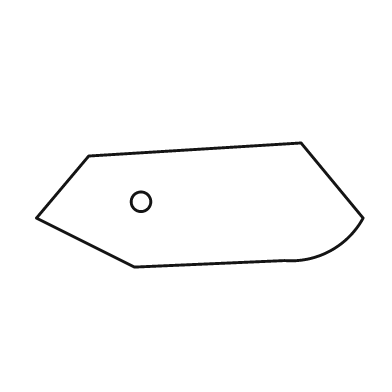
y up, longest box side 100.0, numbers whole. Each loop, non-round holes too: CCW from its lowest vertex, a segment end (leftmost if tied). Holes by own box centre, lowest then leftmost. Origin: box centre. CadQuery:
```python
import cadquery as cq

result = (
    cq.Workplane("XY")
    .moveTo(-20.0, -19.0)
    .lineTo(26.0, -17.0)
    .threePointArc((40.0, -14.0), (50.0, -4.0))
    .lineTo(31.0, 19.0)
    .lineTo(-34.0, 15.0)
    .lineTo(-50.0, -4.0)
    .close()
    .moveTo(-18.0, 1.0)
    .circle(3.0)
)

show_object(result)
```